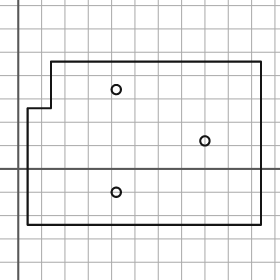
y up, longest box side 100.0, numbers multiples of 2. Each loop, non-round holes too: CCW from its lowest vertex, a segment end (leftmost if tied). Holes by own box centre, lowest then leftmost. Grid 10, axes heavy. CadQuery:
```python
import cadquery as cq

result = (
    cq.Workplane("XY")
    .moveTo(4.0, -24.0)
    .lineTo(104.0, -24.0)
    .lineTo(104.0, 46.0)
    .lineTo(14.0, 46.0)
    .lineTo(14.0, 26.0)
    .lineTo(4.0, 26.0)
    .close()
    .moveTo(42.0, -10.0)
    .circle(2.0)
    .moveTo(80.0, 12.0)
    .circle(2.0)
    .moveTo(42.0, 34.0)
    .circle(2.0)
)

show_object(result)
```